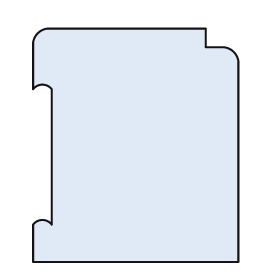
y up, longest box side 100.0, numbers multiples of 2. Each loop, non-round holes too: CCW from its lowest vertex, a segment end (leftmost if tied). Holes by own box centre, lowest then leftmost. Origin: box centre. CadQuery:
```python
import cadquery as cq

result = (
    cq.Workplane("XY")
    .moveTo(-44.0, -50.0)
    .lineTo(44.0, -50.0)
    .lineTo(44.0, 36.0)
    .threePointArc((42.0, 40.0), (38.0, 42.0))
    .lineTo(30.0, 42.0)
    .lineTo(30.0, 50.0)
    .lineTo(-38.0, 50.0)
    .threePointArc((-42.0, 48.0), (-44.0, 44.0))
    .lineTo(-44.0, 24.0)
    .threePointArc((-40.0, 26.0), (-36.0, 24.0))
    .lineTo(-36.0, -34.0)
    .threePointArc((-40.0, -32.0), (-44.0, -34.0))
    .close()
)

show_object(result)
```